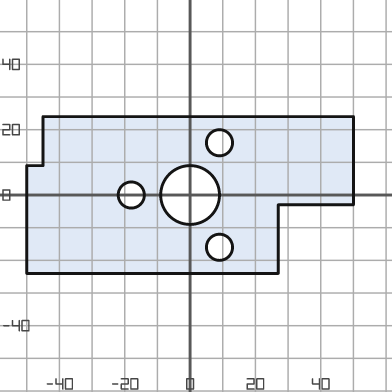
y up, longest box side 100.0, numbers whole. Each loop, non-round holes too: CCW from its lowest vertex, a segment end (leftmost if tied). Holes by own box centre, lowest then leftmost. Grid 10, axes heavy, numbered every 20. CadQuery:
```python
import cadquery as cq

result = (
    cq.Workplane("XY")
    .moveTo(-50.0, -24.0)
    .lineTo(27.0, -24.0)
    .lineTo(27.0, -3.0)
    .lineTo(50.0, -3.0)
    .lineTo(50.0, 24.0)
    .lineTo(-45.0, 24.0)
    .lineTo(-45.0, 9.0)
    .lineTo(-50.0, 9.0)
    .close()
    .moveTo(9.0, -16.0)
    .circle(4.0)
    .moveTo(-18.0, 0.0)
    .circle(4.0)
    .moveTo(0.0, 0.0)
    .circle(9.0)
    .moveTo(9.0, 16.0)
    .circle(4.0)
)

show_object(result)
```